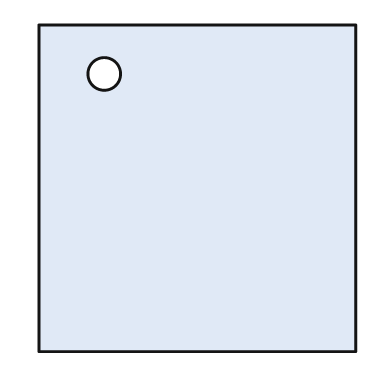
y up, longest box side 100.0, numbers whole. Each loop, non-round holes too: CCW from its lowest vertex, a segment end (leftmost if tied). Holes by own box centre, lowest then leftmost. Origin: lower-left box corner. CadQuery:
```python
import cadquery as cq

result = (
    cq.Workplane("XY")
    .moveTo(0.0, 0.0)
    .lineTo(97.0, 0.0)
    .lineTo(97.0, 100.0)
    .lineTo(0.0, 100.0)
    .close()
    .moveTo(20.0, 85.0)
    .circle(5.0)
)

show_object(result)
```